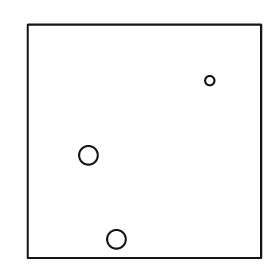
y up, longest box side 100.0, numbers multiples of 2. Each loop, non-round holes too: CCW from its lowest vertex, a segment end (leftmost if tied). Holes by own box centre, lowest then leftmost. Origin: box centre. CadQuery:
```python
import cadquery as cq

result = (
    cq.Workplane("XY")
    .moveTo(-50.0, -50.0)
    .lineTo(50.0, -50.0)
    .lineTo(50.0, 50.0)
    .lineTo(-50.0, 50.0)
    .close()
    .moveTo(-12.0, -42.0)
    .circle(4.0)
    .moveTo(-24.0, -6.0)
    .circle(4.0)
    .moveTo(28.0, 26.0)
    .circle(2.0)
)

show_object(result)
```